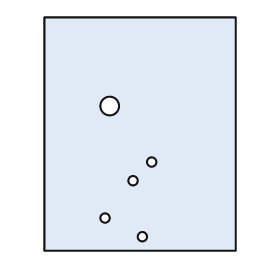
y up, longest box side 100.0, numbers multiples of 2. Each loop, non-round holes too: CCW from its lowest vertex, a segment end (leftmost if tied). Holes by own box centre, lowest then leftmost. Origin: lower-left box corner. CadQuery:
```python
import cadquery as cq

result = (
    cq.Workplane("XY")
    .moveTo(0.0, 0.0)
    .lineTo(82.0, 0.0)
    .lineTo(82.0, 100.0)
    .lineTo(0.0, 100.0)
    .close()
    .moveTo(42.0, 6.0)
    .circle(2.0)
    .moveTo(26.0, 14.0)
    .circle(2.0)
    .moveTo(38.0, 30.0)
    .circle(2.0)
    .moveTo(46.0, 38.0)
    .circle(2.0)
    .moveTo(28.0, 62.0)
    .circle(4.0)
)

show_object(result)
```